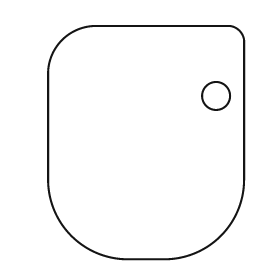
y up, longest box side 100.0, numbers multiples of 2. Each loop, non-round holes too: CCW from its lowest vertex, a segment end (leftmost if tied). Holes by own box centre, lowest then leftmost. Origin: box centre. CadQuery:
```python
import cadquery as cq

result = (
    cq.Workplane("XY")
    .moveTo(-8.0, -50.0)
    .lineTo(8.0, -50.0)
    .threePointArc((32.0, -40.0), (42.0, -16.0))
    .lineTo(42.0, 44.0)
    .threePointArc((40.0, 48.0), (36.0, 50.0))
    .lineTo(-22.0, 50.0)
    .threePointArc((-36.0, 44.0), (-42.0, 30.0))
    .lineTo(-42.0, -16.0)
    .threePointArc((-32.0, -40.0), (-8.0, -50.0))
    .close()
    .moveTo(30.0, 20.0)
    .circle(6.0)
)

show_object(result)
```